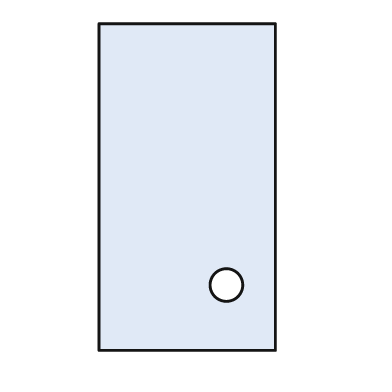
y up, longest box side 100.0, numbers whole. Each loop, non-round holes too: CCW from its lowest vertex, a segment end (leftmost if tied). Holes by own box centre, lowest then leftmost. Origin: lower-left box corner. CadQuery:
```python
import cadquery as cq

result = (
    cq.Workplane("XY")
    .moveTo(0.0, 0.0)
    .lineTo(54.0, 0.0)
    .lineTo(54.0, 100.0)
    .lineTo(0.0, 100.0)
    .close()
    .moveTo(39.0, 20.0)
    .circle(5.0)
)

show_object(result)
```